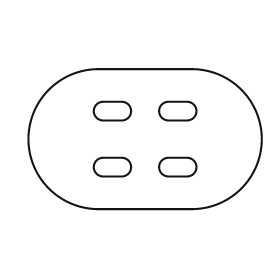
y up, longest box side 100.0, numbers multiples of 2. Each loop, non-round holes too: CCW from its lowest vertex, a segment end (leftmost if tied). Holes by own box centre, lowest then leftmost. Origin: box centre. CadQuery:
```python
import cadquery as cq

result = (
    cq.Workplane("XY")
    .moveTo(-20.0, -30.0)
    .lineTo(20.0, -30.0)
    .threePointArc((50.0, 0.0), (20.0, 30.0))
    .lineTo(-20.0, 30.0)
    .threePointArc((-50.0, 0.0), (-20.0, -30.0))
    .close()
    .moveTo(-18.0, -16.0)
    .lineTo(-10.0, -16.0)
    .threePointArc((-6.0, -12.0), (-10.0, -8.0))
    .lineTo(-18.0, -8.0)
    .threePointArc((-22.0, -12.0), (-18.0, -16.0))
    .close()
    .moveTo(10.0, -16.0)
    .lineTo(18.0, -16.0)
    .threePointArc((22.0, -12.0), (18.0, -8.0))
    .lineTo(10.0, -8.0)
    .threePointArc((6.0, -12.0), (10.0, -16.0))
    .close()
    .moveTo(-18.0, 8.0)
    .lineTo(-10.0, 8.0)
    .threePointArc((-6.0, 12.0), (-10.0, 16.0))
    .lineTo(-18.0, 16.0)
    .threePointArc((-22.0, 12.0), (-18.0, 8.0))
    .close()
    .moveTo(10.0, 8.0)
    .lineTo(18.0, 8.0)
    .threePointArc((22.0, 12.0), (18.0, 16.0))
    .lineTo(10.0, 16.0)
    .threePointArc((6.0, 12.0), (10.0, 8.0))
    .close()
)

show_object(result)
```